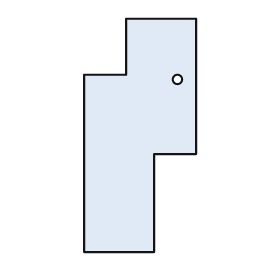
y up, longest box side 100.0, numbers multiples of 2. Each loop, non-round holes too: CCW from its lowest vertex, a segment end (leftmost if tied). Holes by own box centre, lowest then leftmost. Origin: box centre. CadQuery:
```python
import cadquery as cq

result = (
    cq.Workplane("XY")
    .moveTo(-24.0, -50.0)
    .lineTo(6.0, -50.0)
    .lineTo(6.0, -8.0)
    .lineTo(24.0, -8.0)
    .lineTo(24.0, 50.0)
    .lineTo(-6.0, 50.0)
    .lineTo(-6.0, 26.0)
    .lineTo(-24.0, 26.0)
    .close()
    .moveTo(16.0, 24.0)
    .circle(2.0)
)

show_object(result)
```